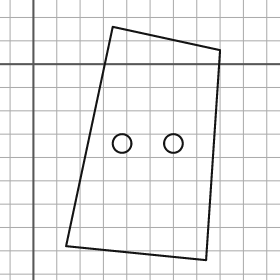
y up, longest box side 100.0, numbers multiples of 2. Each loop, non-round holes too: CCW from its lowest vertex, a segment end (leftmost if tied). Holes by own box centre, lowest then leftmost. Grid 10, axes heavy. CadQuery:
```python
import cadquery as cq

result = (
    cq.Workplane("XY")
    .moveTo(74.0, -84.0)
    .lineTo(80.0, 6.0)
    .lineTo(34.0, 16.0)
    .lineTo(14.0, -78.0)
    .close()
    .moveTo(38.0, -34.0)
    .circle(4.0)
    .moveTo(60.0, -34.0)
    .circle(4.0)
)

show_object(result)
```